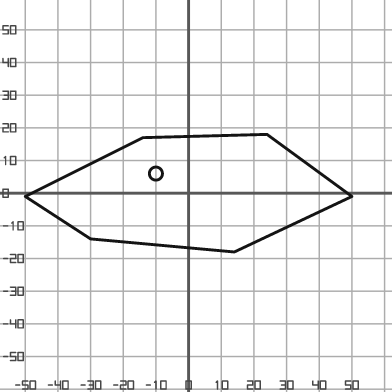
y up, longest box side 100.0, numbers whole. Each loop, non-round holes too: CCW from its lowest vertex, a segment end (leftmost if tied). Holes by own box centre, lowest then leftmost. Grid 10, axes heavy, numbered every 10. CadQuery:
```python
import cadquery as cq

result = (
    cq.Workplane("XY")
    .moveTo(14.0, -18.0)
    .lineTo(50.0, -1.0)
    .lineTo(24.0, 18.0)
    .lineTo(-14.0, 17.0)
    .lineTo(-50.0, -1.0)
    .lineTo(-30.0, -14.0)
    .close()
    .moveTo(-10.0, 6.0)
    .circle(2.0)
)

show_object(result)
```